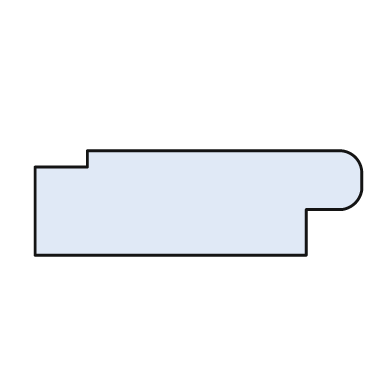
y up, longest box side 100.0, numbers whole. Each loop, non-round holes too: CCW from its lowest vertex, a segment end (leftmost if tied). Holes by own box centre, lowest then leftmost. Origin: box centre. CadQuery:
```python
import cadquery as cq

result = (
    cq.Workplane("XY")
    .moveTo(-50.0, -16.0)
    .lineTo(33.0, -16.0)
    .lineTo(33.0, -2.0)
    .lineTo(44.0, -2.0)
    .threePointArc((48.0, 0.0), (50.0, 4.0))
    .lineTo(50.0, 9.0)
    .threePointArc((48.0, 14.0), (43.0, 16.0))
    .lineTo(-34.0, 16.0)
    .lineTo(-34.0, 11.0)
    .lineTo(-50.0, 11.0)
    .close()
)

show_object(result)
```